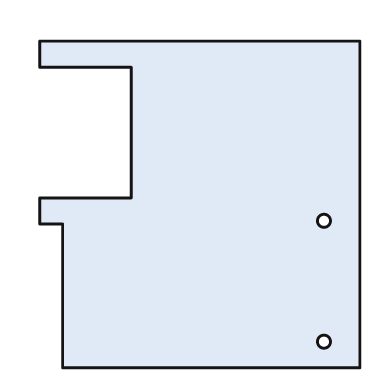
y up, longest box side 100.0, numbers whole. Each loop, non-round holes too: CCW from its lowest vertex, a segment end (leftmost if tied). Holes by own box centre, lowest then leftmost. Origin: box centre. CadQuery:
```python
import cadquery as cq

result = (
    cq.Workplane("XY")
    .moveTo(-42.0, -50.0)
    .lineTo(49.0, -50.0)
    .lineTo(49.0, 50.0)
    .lineTo(-49.0, 50.0)
    .lineTo(-49.0, 42.0)
    .lineTo(-21.0, 42.0)
    .lineTo(-21.0, 2.0)
    .lineTo(-49.0, 2.0)
    .lineTo(-49.0, -6.0)
    .lineTo(-42.0, -6.0)
    .close()
    .moveTo(38.0, -42.0)
    .circle(2.0)
    .moveTo(38.0, -5.0)
    .circle(2.0)
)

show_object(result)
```